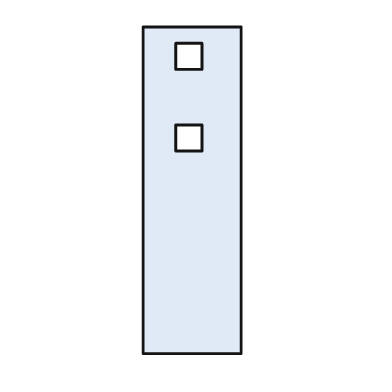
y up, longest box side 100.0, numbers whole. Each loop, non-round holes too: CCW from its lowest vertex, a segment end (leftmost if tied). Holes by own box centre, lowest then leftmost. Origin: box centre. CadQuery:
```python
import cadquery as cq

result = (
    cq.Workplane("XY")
    .moveTo(-15.0, -50.0)
    .lineTo(15.0, -50.0)
    .lineTo(15.0, 50.0)
    .lineTo(-15.0, 50.0)
    .close()
    .moveTo(-5.0, 12.0)
    .lineTo(3.0, 12.0)
    .lineTo(3.0, 20.0)
    .lineTo(-5.0, 20.0)
    .close()
    .moveTo(-5.0, 37.0)
    .lineTo(3.0, 37.0)
    .lineTo(3.0, 45.0)
    .lineTo(-5.0, 45.0)
    .close()
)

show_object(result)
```